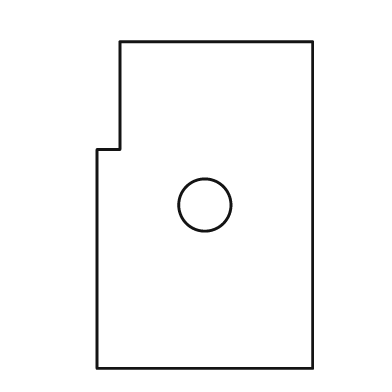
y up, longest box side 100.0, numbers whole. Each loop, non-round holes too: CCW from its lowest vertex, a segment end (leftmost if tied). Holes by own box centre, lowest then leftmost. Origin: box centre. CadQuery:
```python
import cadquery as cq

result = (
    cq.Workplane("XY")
    .moveTo(-33.0, -50.0)
    .lineTo(33.0, -50.0)
    .lineTo(33.0, 50.0)
    .lineTo(-26.0, 50.0)
    .lineTo(-26.0, 17.0)
    .lineTo(-33.0, 17.0)
    .close()
    .moveTo(0.0, 0.0)
    .circle(8.0)
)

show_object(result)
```